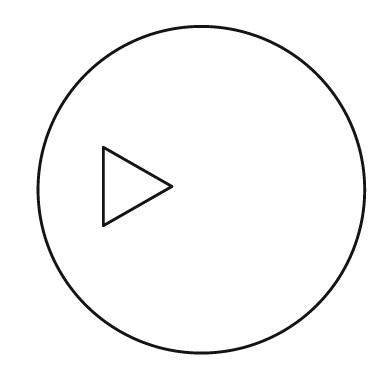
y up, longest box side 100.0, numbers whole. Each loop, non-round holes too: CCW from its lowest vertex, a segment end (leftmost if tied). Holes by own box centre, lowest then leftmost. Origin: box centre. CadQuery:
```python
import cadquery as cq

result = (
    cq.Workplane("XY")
    .moveTo(0.0, 0.0)
    .circle(50.0)
    .moveTo(-30.0, -11.0)
    .lineTo(-9.0, 1.0)
    .lineTo(-30.0, 13.0)
    .close()
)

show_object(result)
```